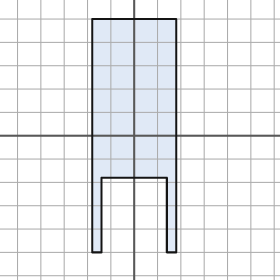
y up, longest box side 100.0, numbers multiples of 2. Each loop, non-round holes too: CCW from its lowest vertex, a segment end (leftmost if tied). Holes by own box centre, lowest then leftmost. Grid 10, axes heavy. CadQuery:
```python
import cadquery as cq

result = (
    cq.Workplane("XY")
    .moveTo(-18.0, -50.0)
    .lineTo(-14.0, -50.0)
    .lineTo(-14.0, -18.0)
    .lineTo(14.0, -18.0)
    .lineTo(14.0, -50.0)
    .lineTo(18.0, -50.0)
    .lineTo(18.0, 50.0)
    .lineTo(-18.0, 50.0)
    .close()
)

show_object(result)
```